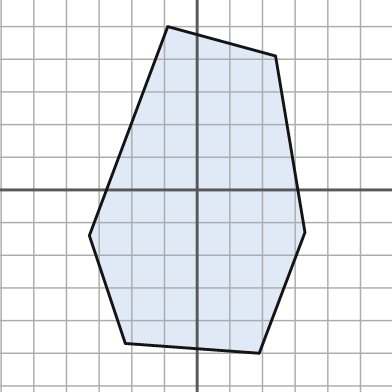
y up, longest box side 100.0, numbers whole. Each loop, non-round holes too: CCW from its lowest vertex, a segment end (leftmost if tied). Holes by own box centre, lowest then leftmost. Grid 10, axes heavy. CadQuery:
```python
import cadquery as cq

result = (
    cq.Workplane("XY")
    .moveTo(19.0, -50.0)
    .lineTo(33.0, -13.0)
    .lineTo(24.0, 41.0)
    .lineTo(-9.0, 50.0)
    .lineTo(-33.0, -14.0)
    .lineTo(-22.0, -47.0)
    .close()
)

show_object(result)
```